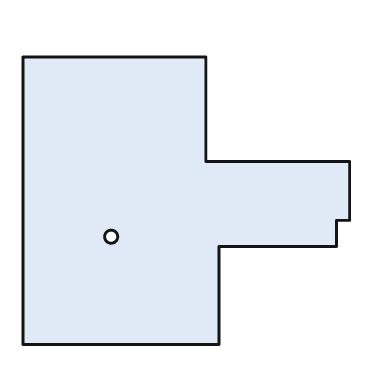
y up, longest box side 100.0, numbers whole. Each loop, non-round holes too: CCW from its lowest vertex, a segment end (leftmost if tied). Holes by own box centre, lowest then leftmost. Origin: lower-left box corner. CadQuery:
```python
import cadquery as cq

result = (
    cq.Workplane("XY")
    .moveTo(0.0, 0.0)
    .lineTo(60.0, 0.0)
    .lineTo(60.0, 30.0)
    .lineTo(96.0, 30.0)
    .lineTo(96.0, 38.0)
    .lineTo(100.0, 38.0)
    .lineTo(100.0, 56.0)
    .lineTo(56.0, 56.0)
    .lineTo(56.0, 88.0)
    .lineTo(0.0, 88.0)
    .close()
    .moveTo(27.0, 33.0)
    .circle(2.0)
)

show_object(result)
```